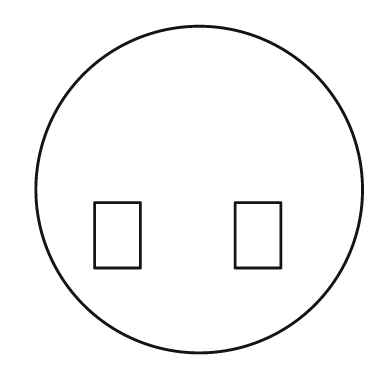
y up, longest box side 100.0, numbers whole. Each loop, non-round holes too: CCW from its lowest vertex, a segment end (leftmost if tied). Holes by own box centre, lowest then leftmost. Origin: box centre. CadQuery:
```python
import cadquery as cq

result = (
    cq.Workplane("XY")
    .moveTo(0.0, 0.0)
    .circle(50.0)
    .moveTo(-32.0, -24.0)
    .lineTo(-18.0, -24.0)
    .lineTo(-18.0, -4.0)
    .lineTo(-32.0, -4.0)
    .close()
    .moveTo(11.0, -24.0)
    .lineTo(25.0, -24.0)
    .lineTo(25.0, -4.0)
    .lineTo(11.0, -4.0)
    .close()
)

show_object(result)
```